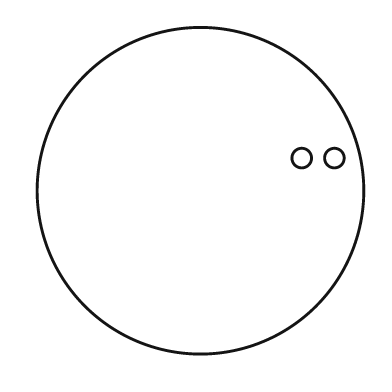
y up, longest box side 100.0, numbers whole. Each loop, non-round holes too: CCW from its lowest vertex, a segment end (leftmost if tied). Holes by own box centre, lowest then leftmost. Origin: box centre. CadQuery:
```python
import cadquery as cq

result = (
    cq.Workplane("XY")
    .moveTo(0.0, 0.0)
    .circle(50.0)
    .moveTo(31.0, 10.0)
    .circle(3.0)
    .moveTo(41.0, 10.0)
    .circle(3.0)
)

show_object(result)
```